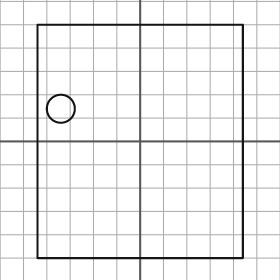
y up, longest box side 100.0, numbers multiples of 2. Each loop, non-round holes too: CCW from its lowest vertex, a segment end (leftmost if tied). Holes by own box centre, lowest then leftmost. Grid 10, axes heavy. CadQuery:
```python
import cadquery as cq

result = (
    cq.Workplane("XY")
    .moveTo(-44.0, -50.0)
    .lineTo(44.0, -50.0)
    .lineTo(44.0, 50.0)
    .lineTo(-44.0, 50.0)
    .close()
    .moveTo(-34.0, 14.0)
    .circle(6.0)
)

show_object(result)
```